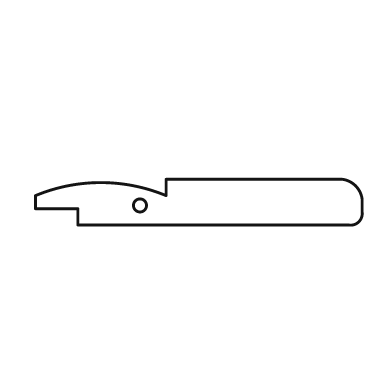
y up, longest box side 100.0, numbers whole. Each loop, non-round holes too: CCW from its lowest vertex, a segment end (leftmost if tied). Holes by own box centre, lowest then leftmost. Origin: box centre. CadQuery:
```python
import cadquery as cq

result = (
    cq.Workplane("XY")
    .moveTo(-37.0, -7.0)
    .lineTo(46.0, -7.0)
    .threePointArc((49.0, -6.0), (50.0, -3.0))
    .lineTo(50.0, 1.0)
    .threePointArc((48.0, 5.0), (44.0, 7.0))
    .lineTo(-10.0, 7.0)
    .lineTo(-10.0, 2.0)
    .threePointArc((-30.0, 6.0), (-50.0, 2.0))
    .lineTo(-50.0, -2.0)
    .lineTo(-37.0, -2.0)
    .close()
    .moveTo(-18.0, -1.0)
    .circle(2.0)
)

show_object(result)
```